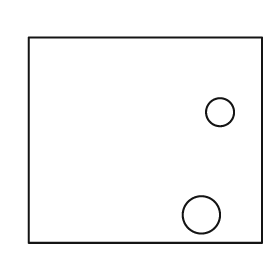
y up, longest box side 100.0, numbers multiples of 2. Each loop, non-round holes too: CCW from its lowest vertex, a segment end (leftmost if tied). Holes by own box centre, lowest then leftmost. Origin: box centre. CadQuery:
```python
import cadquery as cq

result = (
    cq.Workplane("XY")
    .moveTo(-50.0, -44.0)
    .lineTo(50.0, -44.0)
    .lineTo(50.0, 44.0)
    .lineTo(-50.0, 44.0)
    .close()
    .moveTo(24.0, -32.0)
    .circle(8.0)
    .moveTo(32.0, 12.0)
    .circle(6.0)
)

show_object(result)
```